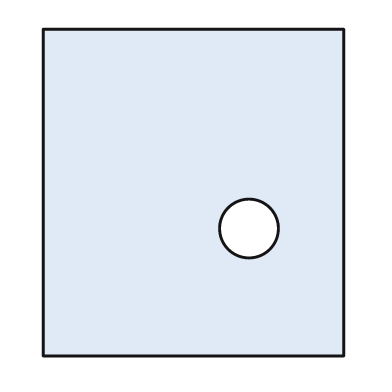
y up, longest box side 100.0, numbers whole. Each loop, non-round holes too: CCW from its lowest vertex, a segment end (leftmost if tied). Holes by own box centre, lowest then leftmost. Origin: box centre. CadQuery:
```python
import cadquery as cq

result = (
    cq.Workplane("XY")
    .moveTo(-46.0, -50.0)
    .lineTo(46.0, -50.0)
    .lineTo(46.0, 50.0)
    .lineTo(-46.0, 50.0)
    .close()
    .moveTo(17.0, -11.0)
    .circle(9.0)
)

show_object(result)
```